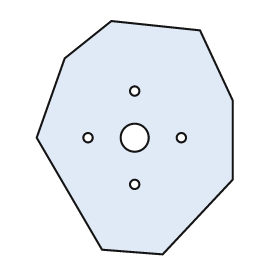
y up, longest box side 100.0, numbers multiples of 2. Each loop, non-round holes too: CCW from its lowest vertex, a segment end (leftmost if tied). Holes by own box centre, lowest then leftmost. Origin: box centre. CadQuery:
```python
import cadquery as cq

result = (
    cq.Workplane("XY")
    .moveTo(12.0, -50.0)
    .lineTo(42.0, -18.0)
    .lineTo(42.0, 16.0)
    .lineTo(28.0, 46.0)
    .lineTo(-10.0, 50.0)
    .lineTo(-30.0, 34.0)
    .lineTo(-42.0, 0.0)
    .lineTo(-14.0, -48.0)
    .close()
    .moveTo(0.0, -20.0)
    .circle(2.0)
    .moveTo(-20.0, 0.0)
    .circle(2.0)
    .moveTo(0.0, 0.0)
    .circle(6.0)
    .moveTo(20.0, 0.0)
    .circle(2.0)
    .moveTo(0.0, 20.0)
    .circle(2.0)
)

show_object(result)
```